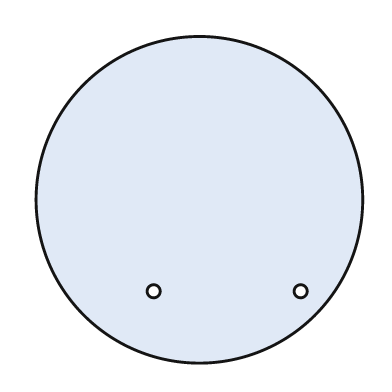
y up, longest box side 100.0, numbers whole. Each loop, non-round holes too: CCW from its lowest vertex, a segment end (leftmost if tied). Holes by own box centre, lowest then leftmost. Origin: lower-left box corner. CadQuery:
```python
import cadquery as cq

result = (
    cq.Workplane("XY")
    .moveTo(50.0, 50.0)
    .circle(50.0)
    .moveTo(36.0, 22.0)
    .circle(2.0)
    .moveTo(81.0, 22.0)
    .circle(2.0)
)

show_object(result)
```